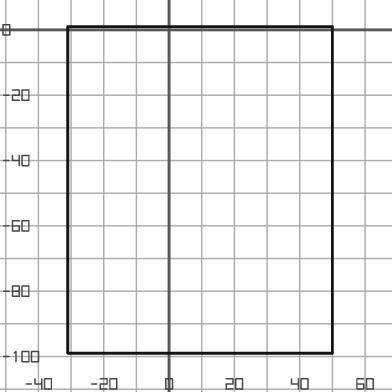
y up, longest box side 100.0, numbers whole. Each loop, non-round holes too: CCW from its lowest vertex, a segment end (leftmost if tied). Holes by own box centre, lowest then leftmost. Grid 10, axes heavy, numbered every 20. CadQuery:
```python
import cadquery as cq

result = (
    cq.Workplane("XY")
    .moveTo(-31.0, -99.0)
    .lineTo(50.0, -99.0)
    .lineTo(50.0, 1.0)
    .lineTo(-31.0, 1.0)
    .close()
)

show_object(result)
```